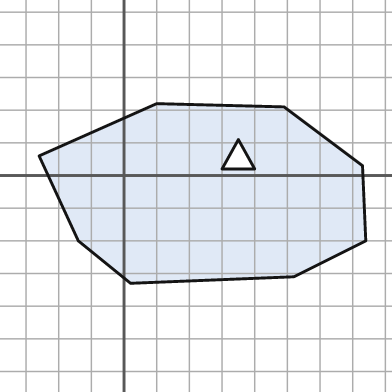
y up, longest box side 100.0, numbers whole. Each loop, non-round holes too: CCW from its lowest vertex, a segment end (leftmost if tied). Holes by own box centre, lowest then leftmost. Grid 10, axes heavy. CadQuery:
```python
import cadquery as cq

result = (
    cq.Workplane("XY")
    .moveTo(2.0, -33.0)
    .lineTo(52.0, -31.0)
    .lineTo(74.0, -20.0)
    .lineTo(73.0, 3.0)
    .lineTo(49.0, 21.0)
    .lineTo(10.0, 22.0)
    .lineTo(-26.0, 6.0)
    .lineTo(-14.0, -20.0)
    .close()
    .moveTo(30.0, 2.0)
    .lineTo(40.0, 2.0)
    .lineTo(35.0, 11.0)
    .close()
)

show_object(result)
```